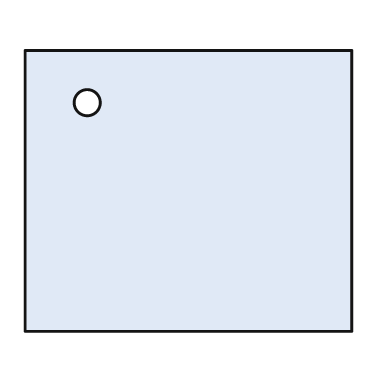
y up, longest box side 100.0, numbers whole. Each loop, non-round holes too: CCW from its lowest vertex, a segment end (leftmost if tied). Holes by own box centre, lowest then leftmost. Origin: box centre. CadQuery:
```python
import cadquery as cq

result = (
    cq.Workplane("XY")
    .moveTo(-50.0, -43.0)
    .lineTo(50.0, -43.0)
    .lineTo(50.0, 43.0)
    .lineTo(-50.0, 43.0)
    .close()
    .moveTo(-31.0, 27.0)
    .circle(4.0)
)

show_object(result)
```